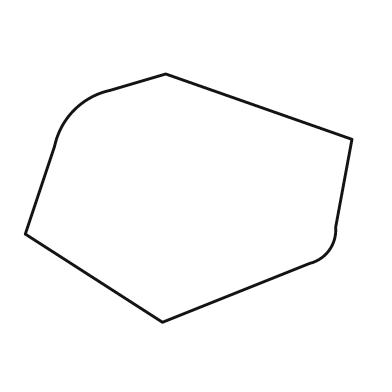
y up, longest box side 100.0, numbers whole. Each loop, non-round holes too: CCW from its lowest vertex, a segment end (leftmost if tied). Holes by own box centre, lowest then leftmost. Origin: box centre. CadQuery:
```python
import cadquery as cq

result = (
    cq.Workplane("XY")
    .moveTo(-8.0, -38.0)
    .lineTo(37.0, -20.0)
    .threePointArc((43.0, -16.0), (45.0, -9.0))
    .lineTo(50.0, 18.0)
    .lineTo(-7.0, 38.0)
    .lineTo(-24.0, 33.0)
    .threePointArc((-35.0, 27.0), (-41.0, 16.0))
    .lineTo(-50.0, -11.0)
    .close()
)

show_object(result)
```